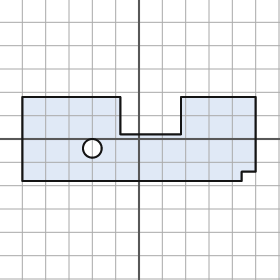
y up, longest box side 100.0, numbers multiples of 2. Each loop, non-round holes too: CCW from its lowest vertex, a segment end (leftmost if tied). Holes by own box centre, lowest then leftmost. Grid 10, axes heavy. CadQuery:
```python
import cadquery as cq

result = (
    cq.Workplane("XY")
    .moveTo(-50.0, -18.0)
    .lineTo(44.0, -18.0)
    .lineTo(44.0, -14.0)
    .lineTo(50.0, -14.0)
    .lineTo(50.0, 18.0)
    .lineTo(18.0, 18.0)
    .lineTo(18.0, 2.0)
    .lineTo(-8.0, 2.0)
    .lineTo(-8.0, 18.0)
    .lineTo(-50.0, 18.0)
    .close()
    .moveTo(-20.0, -4.0)
    .circle(4.0)
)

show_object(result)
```